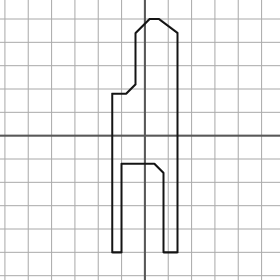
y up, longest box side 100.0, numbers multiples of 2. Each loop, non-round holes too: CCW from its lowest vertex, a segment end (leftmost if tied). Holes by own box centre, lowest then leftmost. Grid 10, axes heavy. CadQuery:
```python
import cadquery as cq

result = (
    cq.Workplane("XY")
    .moveTo(-14.0, -50.0)
    .lineTo(-10.0, -50.0)
    .lineTo(-10.0, -12.0)
    .lineTo(4.0, -12.0)
    .lineTo(8.0, -16.0)
    .lineTo(8.0, -50.0)
    .lineTo(14.0, -50.0)
    .lineTo(14.0, 44.0)
    .lineTo(6.0, 50.0)
    .lineTo(2.0, 50.0)
    .lineTo(-4.0, 44.0)
    .lineTo(-4.0, 22.0)
    .lineTo(-8.0, 18.0)
    .lineTo(-14.0, 18.0)
    .close()
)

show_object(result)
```